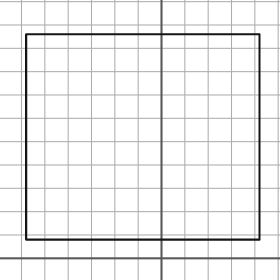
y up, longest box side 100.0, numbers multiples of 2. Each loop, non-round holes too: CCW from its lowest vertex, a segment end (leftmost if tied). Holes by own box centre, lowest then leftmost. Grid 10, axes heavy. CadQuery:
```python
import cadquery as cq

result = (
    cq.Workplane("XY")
    .moveTo(-58.0, 8.0)
    .lineTo(42.0, 8.0)
    .lineTo(42.0, 96.0)
    .lineTo(-58.0, 96.0)
    .close()
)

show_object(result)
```